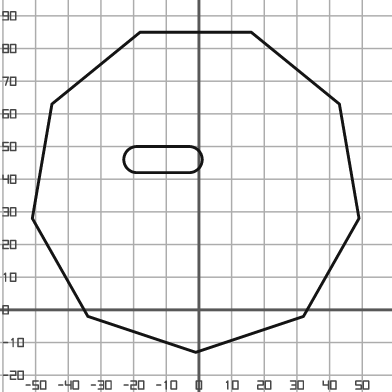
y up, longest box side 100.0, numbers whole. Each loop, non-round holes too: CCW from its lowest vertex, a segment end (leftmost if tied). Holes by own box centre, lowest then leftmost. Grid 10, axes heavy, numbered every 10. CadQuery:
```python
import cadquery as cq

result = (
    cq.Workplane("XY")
    .moveTo(-1.0, -13.0)
    .lineTo(32.0, -2.0)
    .lineTo(49.0, 28.0)
    .lineTo(43.0, 63.0)
    .lineTo(16.0, 85.0)
    .lineTo(-18.0, 85.0)
    .lineTo(-45.0, 63.0)
    .lineTo(-51.0, 28.0)
    .lineTo(-34.0, -2.0)
    .close()
    .moveTo(-19.0, 42.0)
    .lineTo(-3.0, 42.0)
    .threePointArc((1.0, 46.0), (-3.0, 50.0))
    .lineTo(-19.0, 50.0)
    .threePointArc((-23.0, 46.0), (-19.0, 42.0))
    .close()
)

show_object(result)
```